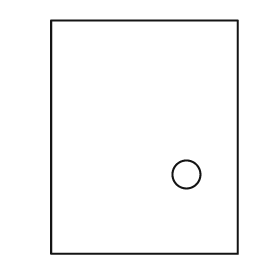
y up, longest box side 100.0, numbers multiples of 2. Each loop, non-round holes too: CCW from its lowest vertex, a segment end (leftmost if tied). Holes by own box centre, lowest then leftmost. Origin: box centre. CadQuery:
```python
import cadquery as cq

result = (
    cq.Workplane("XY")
    .moveTo(-40.0, -50.0)
    .lineTo(40.0, -50.0)
    .lineTo(40.0, 50.0)
    .lineTo(-40.0, 50.0)
    .close()
    .moveTo(18.0, -16.0)
    .circle(6.0)
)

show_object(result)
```